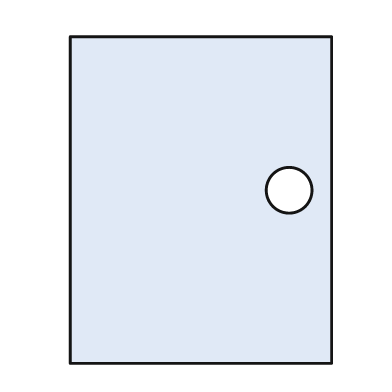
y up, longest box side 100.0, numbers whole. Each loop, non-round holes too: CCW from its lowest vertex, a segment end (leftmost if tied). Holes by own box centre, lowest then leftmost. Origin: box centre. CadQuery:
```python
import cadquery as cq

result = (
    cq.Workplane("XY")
    .moveTo(-40.0, -50.0)
    .lineTo(40.0, -50.0)
    .lineTo(40.0, 50.0)
    .lineTo(-40.0, 50.0)
    .close()
    .moveTo(27.0, 3.0)
    .circle(7.0)
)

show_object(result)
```